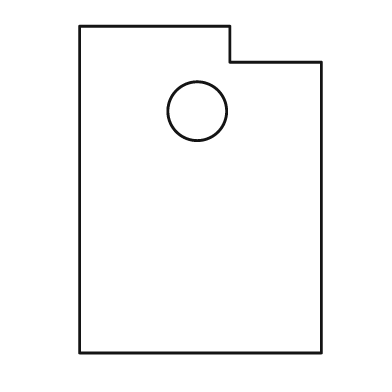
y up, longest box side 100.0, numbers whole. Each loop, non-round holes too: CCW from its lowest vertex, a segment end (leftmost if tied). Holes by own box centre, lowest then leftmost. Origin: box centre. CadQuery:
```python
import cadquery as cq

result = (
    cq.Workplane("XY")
    .moveTo(-37.0, -50.0)
    .lineTo(37.0, -50.0)
    .lineTo(37.0, 39.0)
    .lineTo(9.0, 39.0)
    .lineTo(9.0, 50.0)
    .lineTo(-37.0, 50.0)
    .close()
    .moveTo(-1.0, 24.0)
    .circle(9.0)
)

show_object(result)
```